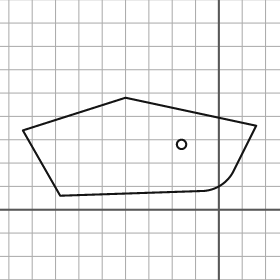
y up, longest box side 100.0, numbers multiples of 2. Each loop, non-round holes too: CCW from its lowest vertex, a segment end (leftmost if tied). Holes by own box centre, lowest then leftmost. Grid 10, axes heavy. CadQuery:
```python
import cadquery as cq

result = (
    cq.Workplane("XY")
    .moveTo(-68.0, 6.0)
    .lineTo(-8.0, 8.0)
    .threePointArc((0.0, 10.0), (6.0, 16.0))
    .lineTo(16.0, 36.0)
    .lineTo(-40.0, 48.0)
    .lineTo(-84.0, 34.0)
    .close()
    .moveTo(-16.0, 28.0)
    .circle(2.0)
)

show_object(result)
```